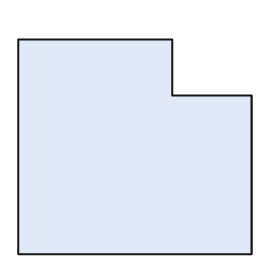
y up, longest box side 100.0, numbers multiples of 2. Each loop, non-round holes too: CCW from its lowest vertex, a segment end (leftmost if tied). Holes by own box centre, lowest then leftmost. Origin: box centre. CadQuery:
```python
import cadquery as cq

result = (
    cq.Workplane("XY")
    .moveTo(-50.0, -46.0)
    .lineTo(50.0, -46.0)
    .lineTo(50.0, 22.0)
    .lineTo(16.0, 22.0)
    .lineTo(16.0, 46.0)
    .lineTo(-50.0, 46.0)
    .close()
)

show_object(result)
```